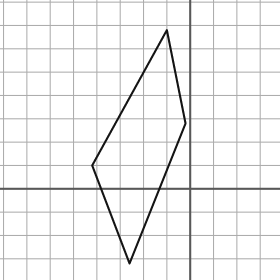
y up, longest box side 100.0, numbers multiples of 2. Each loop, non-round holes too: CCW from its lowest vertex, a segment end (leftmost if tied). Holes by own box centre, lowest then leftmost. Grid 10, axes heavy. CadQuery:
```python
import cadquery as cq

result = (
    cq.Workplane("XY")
    .moveTo(-26.0, -32.0)
    .lineTo(-2.0, 28.0)
    .lineTo(-10.0, 68.0)
    .lineTo(-42.0, 10.0)
    .close()
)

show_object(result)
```